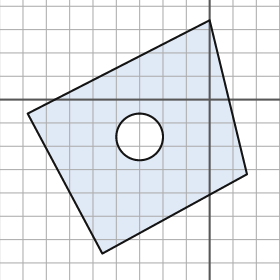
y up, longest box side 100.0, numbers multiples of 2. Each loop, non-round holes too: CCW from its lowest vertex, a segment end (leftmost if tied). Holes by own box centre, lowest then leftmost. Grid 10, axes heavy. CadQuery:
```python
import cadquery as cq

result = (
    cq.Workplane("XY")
    .moveTo(-46.0, -66.0)
    .lineTo(16.0, -32.0)
    .lineTo(0.0, 34.0)
    .lineTo(-78.0, -6.0)
    .close()
    .moveTo(-30.0, -16.0)
    .circle(10.0)
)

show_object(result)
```